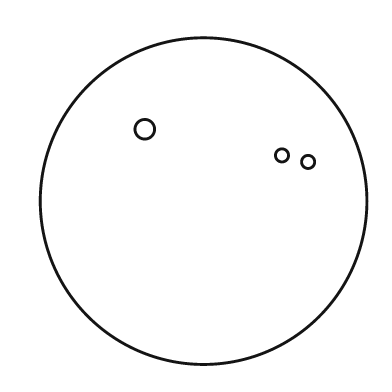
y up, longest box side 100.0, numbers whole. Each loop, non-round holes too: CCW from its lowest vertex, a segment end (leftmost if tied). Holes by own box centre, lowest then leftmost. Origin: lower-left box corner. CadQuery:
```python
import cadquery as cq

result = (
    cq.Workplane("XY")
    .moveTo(50.0, 50.0)
    .circle(50.0)
    .moveTo(82.0, 62.0)
    .circle(2.0)
    .moveTo(74.0, 64.0)
    .circle(2.0)
    .moveTo(32.0, 72.0)
    .circle(3.0)
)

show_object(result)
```